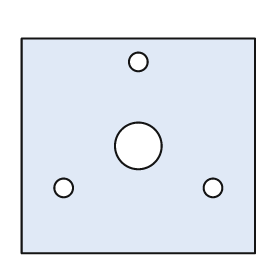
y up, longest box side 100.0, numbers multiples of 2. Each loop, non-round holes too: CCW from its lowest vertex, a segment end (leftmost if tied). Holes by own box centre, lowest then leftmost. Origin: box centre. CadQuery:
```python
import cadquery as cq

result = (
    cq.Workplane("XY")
    .moveTo(-50.0, -46.0)
    .lineTo(50.0, -46.0)
    .lineTo(50.0, 46.0)
    .lineTo(-50.0, 46.0)
    .close()
    .moveTo(-32.0, -18.0)
    .circle(4.0)
    .moveTo(32.0, -18.0)
    .circle(4.0)
    .moveTo(0.0, 0.0)
    .circle(10.0)
    .moveTo(0.0, 36.0)
    .circle(4.0)
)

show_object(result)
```